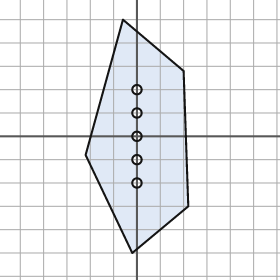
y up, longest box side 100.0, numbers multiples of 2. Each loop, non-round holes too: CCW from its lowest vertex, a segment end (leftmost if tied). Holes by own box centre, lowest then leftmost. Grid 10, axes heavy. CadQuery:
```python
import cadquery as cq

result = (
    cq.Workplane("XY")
    .moveTo(-2.0, -50.0)
    .lineTo(22.0, -30.0)
    .lineTo(20.0, 28.0)
    .lineTo(-6.0, 50.0)
    .lineTo(-22.0, -8.0)
    .close()
    .moveTo(0.0, -20.0)
    .circle(2.0)
    .moveTo(0.0, -10.0)
    .circle(2.0)
    .moveTo(0.0, 0.0)
    .circle(2.0)
    .moveTo(0.0, 10.0)
    .circle(2.0)
    .moveTo(0.0, 20.0)
    .circle(2.0)
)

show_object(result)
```